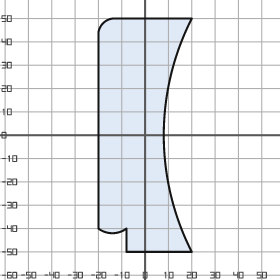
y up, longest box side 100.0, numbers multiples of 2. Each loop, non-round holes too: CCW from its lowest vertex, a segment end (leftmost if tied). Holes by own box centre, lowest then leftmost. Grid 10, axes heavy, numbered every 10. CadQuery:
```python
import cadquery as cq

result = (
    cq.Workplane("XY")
    .moveTo(-8.0, -50.0)
    .lineTo(20.0, -50.0)
    .threePointArc((8.0, 0.0), (20.0, 50.0))
    .lineTo(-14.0, 50.0)
    .threePointArc((-18.0, 48.0), (-20.0, 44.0))
    .lineTo(-20.0, -40.0)
    .threePointArc((-14.0, -42.0), (-8.0, -40.0))
    .close()
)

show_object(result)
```